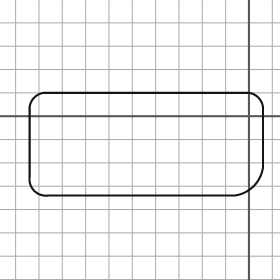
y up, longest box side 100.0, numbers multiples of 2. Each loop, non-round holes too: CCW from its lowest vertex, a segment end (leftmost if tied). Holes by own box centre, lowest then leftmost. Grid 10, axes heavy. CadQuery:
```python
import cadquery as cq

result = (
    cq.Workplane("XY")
    .moveTo(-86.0, -34.0)
    .lineTo(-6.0, -34.0)
    .threePointArc((2.0, -30.0), (6.0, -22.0))
    .lineTo(6.0, 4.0)
    .threePointArc((4.0, 8.0), (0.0, 10.0))
    .lineTo(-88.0, 10.0)
    .threePointArc((-92.0, 8.0), (-94.0, 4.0))
    .lineTo(-94.0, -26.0)
    .threePointArc((-92.0, -32.0), (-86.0, -34.0))
    .close()
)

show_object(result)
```